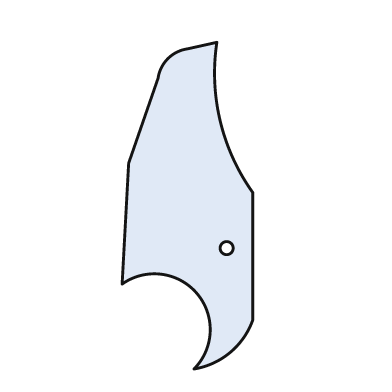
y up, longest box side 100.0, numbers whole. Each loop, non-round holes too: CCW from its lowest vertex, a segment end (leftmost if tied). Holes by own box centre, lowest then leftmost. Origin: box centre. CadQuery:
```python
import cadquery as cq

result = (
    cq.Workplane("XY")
    .moveTo(2.0, -50.0)
    .threePointArc((13.0, -45.0), (20.0, -35.0))
    .lineTo(20.0, 4.0)
    .threePointArc((10.0, 26.0), (9.0, 50.0))
    .lineTo(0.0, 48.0)
    .threePointArc((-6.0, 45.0), (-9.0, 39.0))
    .lineTo(-18.0, 13.0)
    .lineTo(-20.0, -24.0)
    .threePointArc((3.0, -27.0), (2.0, -50.0))
    .close()
    .moveTo(12.0, -13.0)
    .circle(2.0)
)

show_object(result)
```